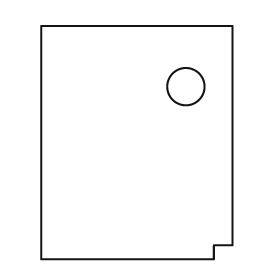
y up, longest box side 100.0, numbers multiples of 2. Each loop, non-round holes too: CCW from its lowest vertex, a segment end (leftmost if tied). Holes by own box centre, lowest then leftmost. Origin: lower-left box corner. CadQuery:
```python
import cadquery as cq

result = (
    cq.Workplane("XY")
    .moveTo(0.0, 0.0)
    .lineTo(74.0, 0.0)
    .lineTo(74.0, 6.0)
    .lineTo(82.0, 6.0)
    .lineTo(82.0, 100.0)
    .lineTo(0.0, 100.0)
    .close()
    .moveTo(62.0, 74.0)
    .circle(8.0)
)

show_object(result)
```